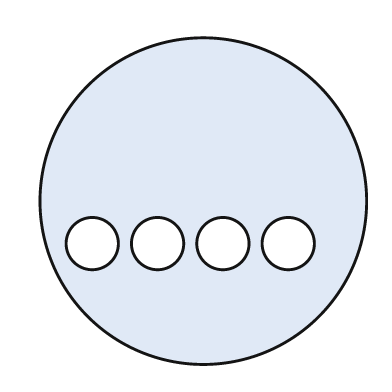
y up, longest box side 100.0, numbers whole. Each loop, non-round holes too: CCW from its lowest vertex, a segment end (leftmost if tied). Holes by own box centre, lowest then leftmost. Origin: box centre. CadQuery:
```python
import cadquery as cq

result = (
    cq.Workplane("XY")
    .moveTo(0.0, 0.0)
    .circle(50.0)
    .moveTo(-34.0, -13.0)
    .circle(8.0)
    .moveTo(-14.0, -13.0)
    .circle(8.0)
    .moveTo(6.0, -13.0)
    .circle(8.0)
    .moveTo(26.0, -13.0)
    .circle(8.0)
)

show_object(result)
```